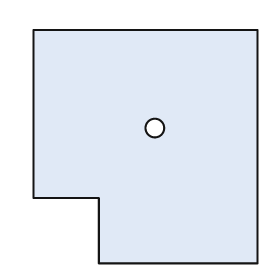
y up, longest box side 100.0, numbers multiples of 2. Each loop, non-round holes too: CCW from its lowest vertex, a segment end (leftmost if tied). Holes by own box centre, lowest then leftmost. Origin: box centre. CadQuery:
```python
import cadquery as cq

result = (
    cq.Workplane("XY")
    .moveTo(-20.0, -50.0)
    .lineTo(48.0, -50.0)
    .lineTo(48.0, 50.0)
    .lineTo(-48.0, 50.0)
    .lineTo(-48.0, -22.0)
    .lineTo(-20.0, -22.0)
    .close()
    .moveTo(4.0, 8.0)
    .circle(4.0)
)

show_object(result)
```